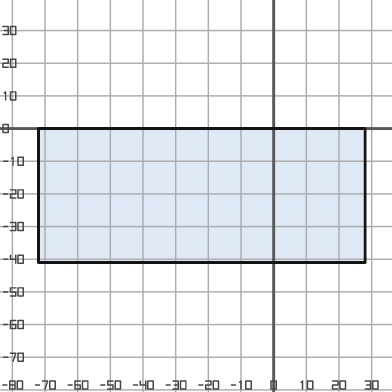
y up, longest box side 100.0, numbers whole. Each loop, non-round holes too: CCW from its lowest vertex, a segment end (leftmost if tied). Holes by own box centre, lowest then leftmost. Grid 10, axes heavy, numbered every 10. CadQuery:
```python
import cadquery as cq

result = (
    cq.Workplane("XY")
    .moveTo(-72.0, -41.0)
    .lineTo(28.0, -41.0)
    .lineTo(28.0, 0.0)
    .lineTo(-72.0, 0.0)
    .close()
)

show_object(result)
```